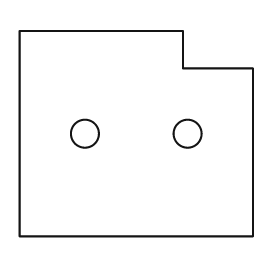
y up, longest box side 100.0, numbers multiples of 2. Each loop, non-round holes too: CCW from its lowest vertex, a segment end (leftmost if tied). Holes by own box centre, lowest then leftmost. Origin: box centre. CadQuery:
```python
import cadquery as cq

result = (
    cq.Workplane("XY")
    .moveTo(-50.0, -44.0)
    .lineTo(50.0, -44.0)
    .lineTo(50.0, 28.0)
    .lineTo(20.0, 28.0)
    .lineTo(20.0, 44.0)
    .lineTo(-50.0, 44.0)
    .close()
    .moveTo(-22.0, 0.0)
    .circle(6.0)
    .moveTo(22.0, 0.0)
    .circle(6.0)
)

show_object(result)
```